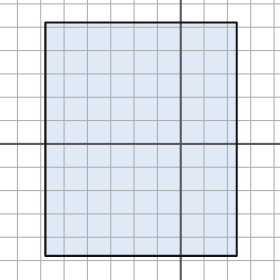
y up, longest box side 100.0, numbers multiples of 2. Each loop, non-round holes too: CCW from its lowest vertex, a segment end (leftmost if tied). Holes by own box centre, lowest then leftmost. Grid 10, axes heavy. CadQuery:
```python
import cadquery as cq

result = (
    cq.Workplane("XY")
    .moveTo(-58.0, -48.0)
    .lineTo(24.0, -48.0)
    .lineTo(24.0, 52.0)
    .lineTo(-58.0, 52.0)
    .close()
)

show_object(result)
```